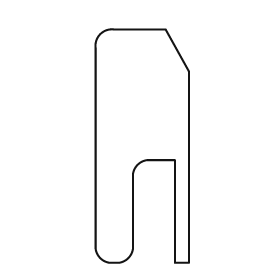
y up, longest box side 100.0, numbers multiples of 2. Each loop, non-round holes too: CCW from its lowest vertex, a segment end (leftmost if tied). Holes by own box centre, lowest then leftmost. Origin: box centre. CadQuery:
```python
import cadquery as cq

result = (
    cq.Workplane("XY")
    .moveTo(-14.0, -50.0)
    .lineTo(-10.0, -50.0)
    .threePointArc((-6.0, -48.0), (-4.0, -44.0))
    .lineTo(-4.0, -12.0)
    .threePointArc((-2.0, -8.0), (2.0, -6.0))
    .lineTo(14.0, -6.0)
    .lineTo(14.0, -50.0)
    .lineTo(20.0, -50.0)
    .lineTo(20.0, 32.0)
    .lineTo(10.0, 50.0)
    .lineTo(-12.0, 50.0)
    .threePointArc((-18.0, 48.0), (-20.0, 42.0))
    .lineTo(-20.0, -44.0)
    .threePointArc((-18.0, -48.0), (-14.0, -50.0))
    .close()
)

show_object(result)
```